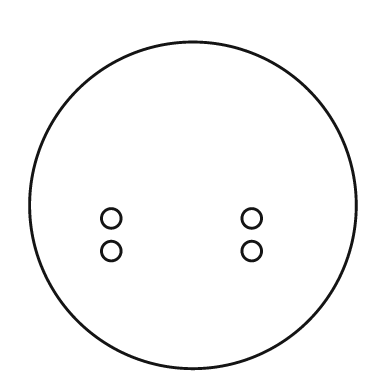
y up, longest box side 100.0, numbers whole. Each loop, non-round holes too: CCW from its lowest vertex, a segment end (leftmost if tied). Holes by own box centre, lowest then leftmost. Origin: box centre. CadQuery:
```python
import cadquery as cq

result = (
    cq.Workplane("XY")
    .moveTo(0.0, 0.0)
    .circle(50.0)
    .moveTo(-25.0, -14.0)
    .circle(3.0)
    .moveTo(18.0, -14.0)
    .circle(3.0)
    .moveTo(-25.0, -4.0)
    .circle(3.0)
    .moveTo(18.0, -4.0)
    .circle(3.0)
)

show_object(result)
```